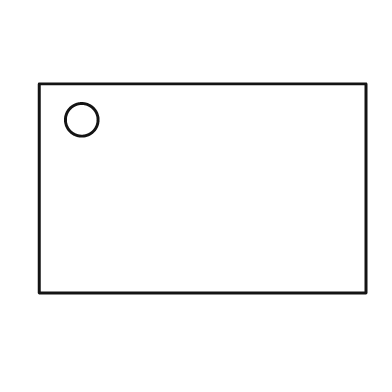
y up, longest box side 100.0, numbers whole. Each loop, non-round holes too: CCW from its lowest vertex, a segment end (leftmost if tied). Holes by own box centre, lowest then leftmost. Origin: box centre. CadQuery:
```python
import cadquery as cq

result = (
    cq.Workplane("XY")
    .moveTo(-50.0, -32.0)
    .lineTo(50.0, -32.0)
    .lineTo(50.0, 32.0)
    .lineTo(-50.0, 32.0)
    .close()
    .moveTo(-37.0, 21.0)
    .circle(5.0)
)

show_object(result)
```